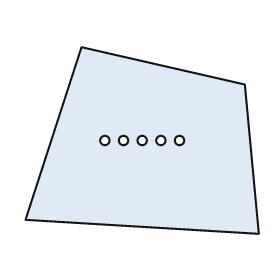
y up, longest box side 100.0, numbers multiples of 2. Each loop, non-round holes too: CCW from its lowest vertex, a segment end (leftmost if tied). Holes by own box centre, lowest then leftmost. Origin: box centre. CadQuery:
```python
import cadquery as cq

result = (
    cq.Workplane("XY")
    .moveTo(50.0, -40.0)
    .lineTo(44.0, 24.0)
    .lineTo(-26.0, 40.0)
    .lineTo(-50.0, -34.0)
    .close()
    .moveTo(-16.0, 0.0)
    .circle(2.0)
    .moveTo(-8.0, 0.0)
    .circle(2.0)
    .moveTo(0.0, 0.0)
    .circle(2.0)
    .moveTo(8.0, 0.0)
    .circle(2.0)
    .moveTo(16.0, 0.0)
    .circle(2.0)
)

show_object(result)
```